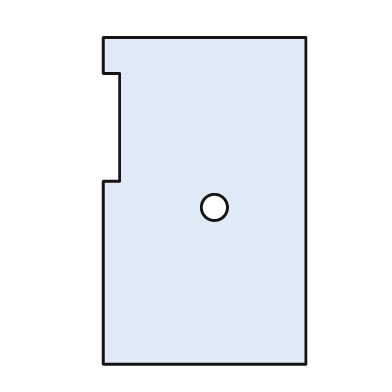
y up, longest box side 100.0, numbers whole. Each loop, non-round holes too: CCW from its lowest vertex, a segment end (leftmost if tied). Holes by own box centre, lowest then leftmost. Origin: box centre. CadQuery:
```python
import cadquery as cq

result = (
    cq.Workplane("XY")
    .moveTo(-31.0, -50.0)
    .lineTo(31.0, -50.0)
    .lineTo(31.0, 50.0)
    .lineTo(-31.0, 50.0)
    .lineTo(-31.0, 39.0)
    .lineTo(-26.0, 39.0)
    .lineTo(-26.0, 6.0)
    .lineTo(-31.0, 6.0)
    .close()
    .moveTo(3.0, -2.0)
    .circle(4.0)
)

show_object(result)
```